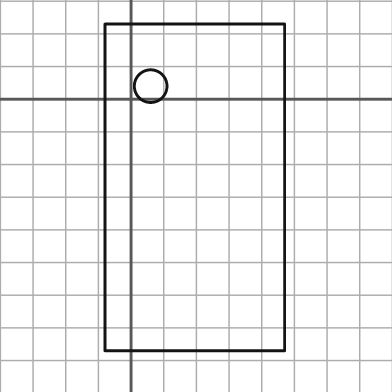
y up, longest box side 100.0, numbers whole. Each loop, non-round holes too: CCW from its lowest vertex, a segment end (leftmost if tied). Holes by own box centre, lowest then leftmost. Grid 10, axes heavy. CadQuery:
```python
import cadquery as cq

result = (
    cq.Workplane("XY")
    .moveTo(-8.0, -77.0)
    .lineTo(47.0, -77.0)
    .lineTo(47.0, 23.0)
    .lineTo(-8.0, 23.0)
    .close()
    .moveTo(6.0, 4.0)
    .circle(5.0)
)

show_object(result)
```